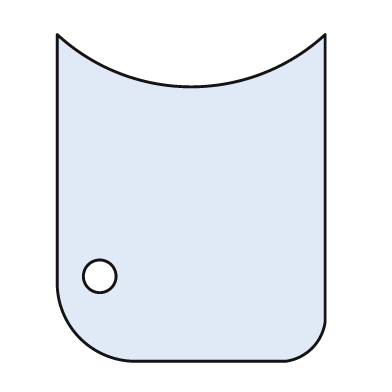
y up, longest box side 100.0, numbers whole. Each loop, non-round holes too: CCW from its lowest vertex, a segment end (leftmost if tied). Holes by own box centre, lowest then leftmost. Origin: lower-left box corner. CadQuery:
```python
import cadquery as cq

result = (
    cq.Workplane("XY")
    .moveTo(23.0, 0.0)
    .lineTo(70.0, 0.0)
    .threePointArc((78.0, 4.0), (82.0, 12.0))
    .lineTo(82.0, 100.0)
    .threePointArc((41.0, 84.0), (0.0, 100.0))
    .lineTo(0.0, 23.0)
    .threePointArc((7.0, 7.0), (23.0, 0.0))
    .close()
    .moveTo(13.0, 26.0)
    .circle(5.0)
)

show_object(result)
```